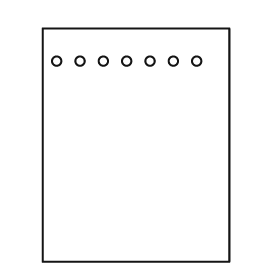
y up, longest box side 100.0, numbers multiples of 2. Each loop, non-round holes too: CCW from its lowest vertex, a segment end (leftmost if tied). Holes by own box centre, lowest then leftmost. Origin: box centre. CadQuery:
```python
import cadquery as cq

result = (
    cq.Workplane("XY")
    .moveTo(-40.0, -50.0)
    .lineTo(40.0, -50.0)
    .lineTo(40.0, 50.0)
    .lineTo(-40.0, 50.0)
    .close()
    .moveTo(-34.0, 36.0)
    .circle(2.0)
    .moveTo(-24.0, 36.0)
    .circle(2.0)
    .moveTo(-14.0, 36.0)
    .circle(2.0)
    .moveTo(-4.0, 36.0)
    .circle(2.0)
    .moveTo(6.0, 36.0)
    .circle(2.0)
    .moveTo(16.0, 36.0)
    .circle(2.0)
    .moveTo(26.0, 36.0)
    .circle(2.0)
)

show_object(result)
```